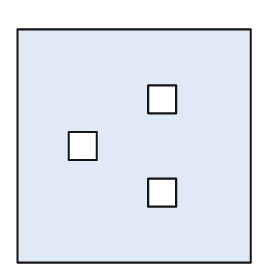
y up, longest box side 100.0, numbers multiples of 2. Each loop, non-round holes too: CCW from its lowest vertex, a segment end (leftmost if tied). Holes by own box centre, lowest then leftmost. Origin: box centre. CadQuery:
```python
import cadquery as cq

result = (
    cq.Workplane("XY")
    .moveTo(-50.0, -50.0)
    .lineTo(50.0, -50.0)
    .lineTo(50.0, 50.0)
    .lineTo(-50.0, 50.0)
    .close()
    .moveTo(6.0, -26.0)
    .lineTo(18.0, -26.0)
    .lineTo(18.0, -14.0)
    .lineTo(6.0, -14.0)
    .close()
    .moveTo(-28.0, -6.0)
    .lineTo(-16.0, -6.0)
    .lineTo(-16.0, 6.0)
    .lineTo(-28.0, 6.0)
    .close()
    .moveTo(6.0, 14.0)
    .lineTo(18.0, 14.0)
    .lineTo(18.0, 26.0)
    .lineTo(6.0, 26.0)
    .close()
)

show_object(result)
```